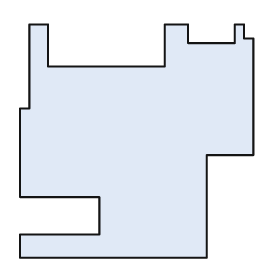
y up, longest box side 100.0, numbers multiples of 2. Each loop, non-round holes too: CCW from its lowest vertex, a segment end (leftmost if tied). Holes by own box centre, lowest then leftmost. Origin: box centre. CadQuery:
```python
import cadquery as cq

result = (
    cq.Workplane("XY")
    .moveTo(-50.0, -50.0)
    .lineTo(30.0, -50.0)
    .lineTo(30.0, -6.0)
    .lineTo(50.0, -6.0)
    .lineTo(50.0, 44.0)
    .lineTo(46.0, 44.0)
    .lineTo(46.0, 50.0)
    .lineTo(42.0, 50.0)
    .lineTo(42.0, 42.0)
    .lineTo(22.0, 42.0)
    .lineTo(22.0, 50.0)
    .lineTo(12.0, 50.0)
    .lineTo(12.0, 32.0)
    .lineTo(-38.0, 32.0)
    .lineTo(-38.0, 50.0)
    .lineTo(-46.0, 50.0)
    .lineTo(-46.0, 14.0)
    .lineTo(-50.0, 14.0)
    .lineTo(-50.0, -24.0)
    .lineTo(-16.0, -24.0)
    .lineTo(-16.0, -40.0)
    .lineTo(-50.0, -40.0)
    .close()
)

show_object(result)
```